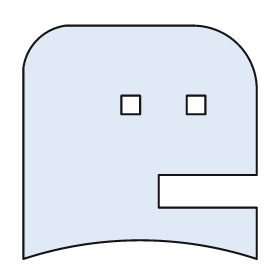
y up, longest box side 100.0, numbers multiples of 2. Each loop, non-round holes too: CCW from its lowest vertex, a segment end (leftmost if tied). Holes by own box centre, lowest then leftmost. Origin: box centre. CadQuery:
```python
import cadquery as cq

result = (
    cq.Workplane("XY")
    .moveTo(-50.0, -50.0)
    .threePointArc((0.0, -42.0), (50.0, -50.0))
    .lineTo(50.0, -28.0)
    .lineTo(8.0, -28.0)
    .lineTo(8.0, -14.0)
    .lineTo(50.0, -14.0)
    .lineTo(50.0, 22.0)
    .threePointArc((42.0, 42.0), (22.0, 50.0))
    .lineTo(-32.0, 50.0)
    .threePointArc((-44.0, 44.0), (-50.0, 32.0))
    .close()
    .moveTo(-8.0, 12.0)
    .lineTo(0.0, 12.0)
    .lineTo(0.0, 20.0)
    .lineTo(-8.0, 20.0)
    .close()
    .moveTo(20.0, 12.0)
    .lineTo(28.0, 12.0)
    .lineTo(28.0, 20.0)
    .lineTo(20.0, 20.0)
    .close()
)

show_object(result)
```